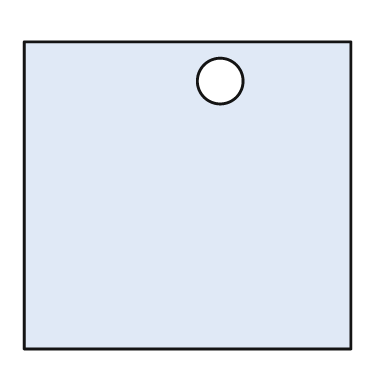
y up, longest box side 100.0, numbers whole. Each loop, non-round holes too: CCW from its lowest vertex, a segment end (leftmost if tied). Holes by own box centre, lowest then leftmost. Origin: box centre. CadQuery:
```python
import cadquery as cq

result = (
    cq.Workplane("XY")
    .moveTo(-50.0, -47.0)
    .lineTo(50.0, -47.0)
    .lineTo(50.0, 47.0)
    .lineTo(-50.0, 47.0)
    .close()
    .moveTo(10.0, 35.0)
    .circle(7.0)
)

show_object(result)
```